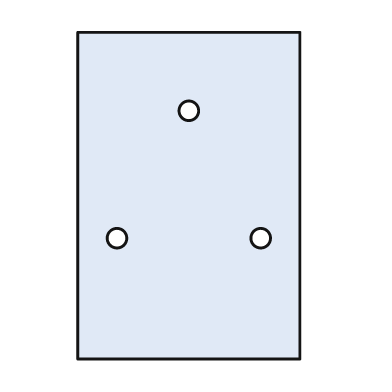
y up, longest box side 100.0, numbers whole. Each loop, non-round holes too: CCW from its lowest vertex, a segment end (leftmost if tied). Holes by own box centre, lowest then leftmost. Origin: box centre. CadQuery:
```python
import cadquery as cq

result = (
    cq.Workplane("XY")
    .moveTo(-34.0, -50.0)
    .lineTo(34.0, -50.0)
    .lineTo(34.0, 50.0)
    .lineTo(-34.0, 50.0)
    .close()
    .moveTo(-22.0, -13.0)
    .circle(3.0)
    .moveTo(22.0, -13.0)
    .circle(3.0)
    .moveTo(0.0, 26.0)
    .circle(3.0)
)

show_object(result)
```